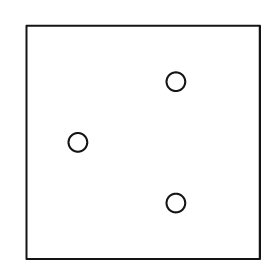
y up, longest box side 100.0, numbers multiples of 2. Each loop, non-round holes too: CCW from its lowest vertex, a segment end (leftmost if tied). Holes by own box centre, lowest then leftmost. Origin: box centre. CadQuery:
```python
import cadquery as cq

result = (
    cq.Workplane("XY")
    .moveTo(-50.0, -50.0)
    .lineTo(50.0, -50.0)
    .lineTo(50.0, 50.0)
    .lineTo(-50.0, 50.0)
    .close()
    .moveTo(14.0, -26.0)
    .circle(4.0)
    .moveTo(-28.0, 0.0)
    .circle(4.0)
    .moveTo(14.0, 26.0)
    .circle(4.0)
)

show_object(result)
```